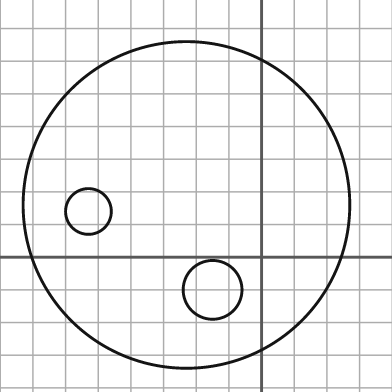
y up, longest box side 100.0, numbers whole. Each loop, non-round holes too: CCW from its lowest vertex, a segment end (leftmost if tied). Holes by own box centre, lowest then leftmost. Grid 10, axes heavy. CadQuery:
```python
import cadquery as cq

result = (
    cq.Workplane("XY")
    .moveTo(-23.0, 16.0)
    .circle(50.0)
    .moveTo(-15.0, -10.0)
    .circle(9.0)
    .moveTo(-53.0, 14.0)
    .circle(7.0)
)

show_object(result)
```